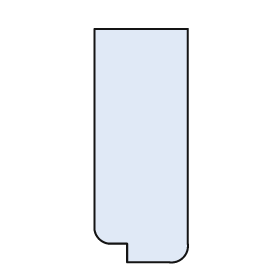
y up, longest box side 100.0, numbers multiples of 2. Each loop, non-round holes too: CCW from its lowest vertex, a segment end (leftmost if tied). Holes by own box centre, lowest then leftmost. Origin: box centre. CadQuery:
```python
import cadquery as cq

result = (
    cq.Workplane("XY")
    .moveTo(-6.0, -50.0)
    .lineTo(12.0, -50.0)
    .threePointArc((18.0, -48.0), (20.0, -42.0))
    .lineTo(20.0, 50.0)
    .lineTo(-20.0, 50.0)
    .lineTo(-20.0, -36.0)
    .threePointArc((-18.0, -40.0), (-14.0, -42.0))
    .lineTo(-6.0, -42.0)
    .close()
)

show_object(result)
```